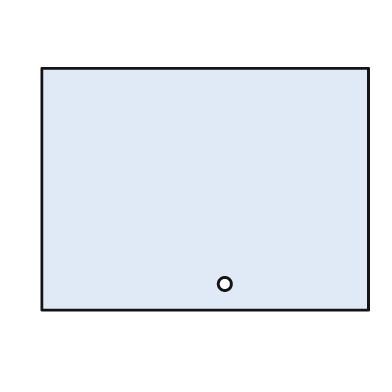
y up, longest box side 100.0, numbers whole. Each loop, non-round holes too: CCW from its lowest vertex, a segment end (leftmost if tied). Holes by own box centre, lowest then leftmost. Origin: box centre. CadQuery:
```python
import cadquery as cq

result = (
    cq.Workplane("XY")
    .moveTo(-50.0, -37.0)
    .lineTo(50.0, -37.0)
    .lineTo(50.0, 37.0)
    .lineTo(-50.0, 37.0)
    .close()
    .moveTo(6.0, -29.0)
    .circle(2.0)
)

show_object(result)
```